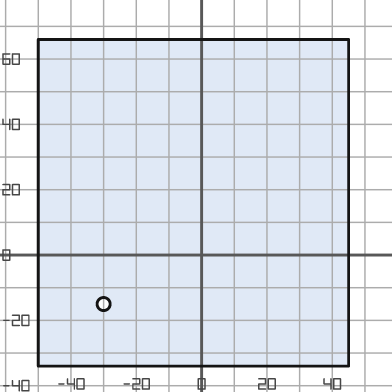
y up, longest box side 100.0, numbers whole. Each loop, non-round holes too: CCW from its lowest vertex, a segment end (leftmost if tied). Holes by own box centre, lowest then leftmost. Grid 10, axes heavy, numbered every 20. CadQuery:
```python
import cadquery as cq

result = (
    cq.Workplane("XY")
    .moveTo(-50.0, -34.0)
    .lineTo(45.0, -34.0)
    .lineTo(45.0, 66.0)
    .lineTo(-50.0, 66.0)
    .close()
    .moveTo(-30.0, -15.0)
    .circle(2.0)
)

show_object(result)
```